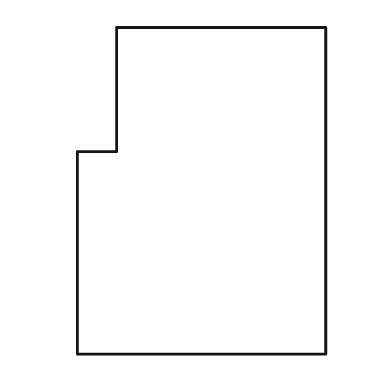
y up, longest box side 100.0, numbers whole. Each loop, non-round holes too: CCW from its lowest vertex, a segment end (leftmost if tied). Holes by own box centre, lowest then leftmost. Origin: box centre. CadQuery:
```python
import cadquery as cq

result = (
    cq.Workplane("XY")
    .moveTo(-38.0, -50.0)
    .lineTo(38.0, -50.0)
    .lineTo(38.0, 50.0)
    .lineTo(-26.0, 50.0)
    .lineTo(-26.0, 12.0)
    .lineTo(-38.0, 12.0)
    .close()
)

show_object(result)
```